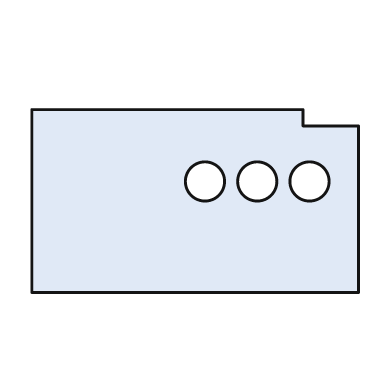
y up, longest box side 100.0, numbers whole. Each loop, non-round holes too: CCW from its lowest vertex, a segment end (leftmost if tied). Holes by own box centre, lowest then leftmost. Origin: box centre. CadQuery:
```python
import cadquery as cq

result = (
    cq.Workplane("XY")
    .moveTo(-50.0, -28.0)
    .lineTo(50.0, -28.0)
    .lineTo(50.0, 23.0)
    .lineTo(33.0, 23.0)
    .lineTo(33.0, 28.0)
    .lineTo(-50.0, 28.0)
    .close()
    .moveTo(3.0, 6.0)
    .circle(6.0)
    .moveTo(19.0, 6.0)
    .circle(6.0)
    .moveTo(35.0, 6.0)
    .circle(6.0)
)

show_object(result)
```